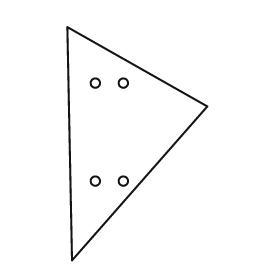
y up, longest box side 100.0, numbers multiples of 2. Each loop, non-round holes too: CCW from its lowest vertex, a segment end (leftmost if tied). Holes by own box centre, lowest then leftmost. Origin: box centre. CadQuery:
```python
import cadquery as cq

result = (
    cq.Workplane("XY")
    .moveTo(-28.0, -50.0)
    .lineTo(30.0, 16.0)
    .lineTo(-30.0, 50.0)
    .close()
    .moveTo(-18.0, -16.0)
    .circle(2.0)
    .moveTo(-6.0, -16.0)
    .circle(2.0)
    .moveTo(-18.0, 26.0)
    .circle(2.0)
    .moveTo(-6.0, 26.0)
    .circle(2.0)
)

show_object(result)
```